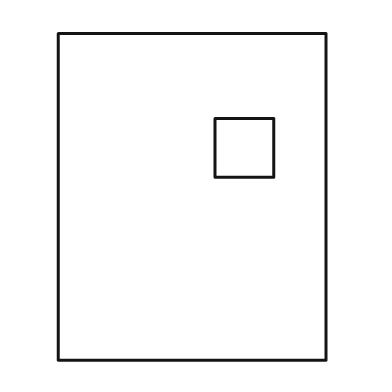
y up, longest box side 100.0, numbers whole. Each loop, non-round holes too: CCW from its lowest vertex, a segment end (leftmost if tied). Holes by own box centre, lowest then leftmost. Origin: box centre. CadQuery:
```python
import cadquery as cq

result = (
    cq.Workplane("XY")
    .moveTo(-41.0, -50.0)
    .lineTo(41.0, -50.0)
    .lineTo(41.0, 50.0)
    .lineTo(-41.0, 50.0)
    .close()
    .moveTo(7.0, 6.0)
    .lineTo(25.0, 6.0)
    .lineTo(25.0, 24.0)
    .lineTo(7.0, 24.0)
    .close()
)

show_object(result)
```